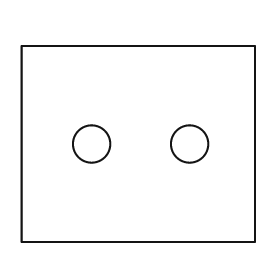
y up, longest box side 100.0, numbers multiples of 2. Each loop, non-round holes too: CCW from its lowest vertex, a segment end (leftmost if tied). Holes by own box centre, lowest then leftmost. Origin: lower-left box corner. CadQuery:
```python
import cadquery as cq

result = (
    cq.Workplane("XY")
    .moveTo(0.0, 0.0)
    .lineTo(100.0, 0.0)
    .lineTo(100.0, 84.0)
    .lineTo(0.0, 84.0)
    .close()
    .moveTo(30.0, 42.0)
    .circle(8.0)
    .moveTo(72.0, 42.0)
    .circle(8.0)
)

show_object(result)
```